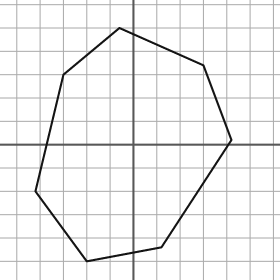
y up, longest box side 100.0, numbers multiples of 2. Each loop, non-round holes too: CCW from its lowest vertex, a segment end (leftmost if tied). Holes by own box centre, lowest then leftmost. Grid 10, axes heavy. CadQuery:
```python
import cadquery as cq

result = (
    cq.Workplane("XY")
    .moveTo(-20.0, -50.0)
    .lineTo(12.0, -44.0)
    .lineTo(42.0, 2.0)
    .lineTo(30.0, 34.0)
    .lineTo(-6.0, 50.0)
    .lineTo(-30.0, 30.0)
    .lineTo(-42.0, -20.0)
    .close()
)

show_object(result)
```